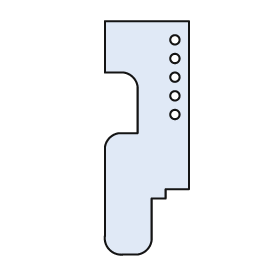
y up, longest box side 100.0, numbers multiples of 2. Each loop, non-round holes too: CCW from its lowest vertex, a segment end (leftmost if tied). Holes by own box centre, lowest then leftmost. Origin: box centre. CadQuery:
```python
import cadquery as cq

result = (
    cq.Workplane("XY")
    .moveTo(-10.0, -50.0)
    .lineTo(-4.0, -50.0)
    .threePointArc((0.0, -48.0), (2.0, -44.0))
    .lineTo(2.0, -26.0)
    .lineTo(8.0, -26.0)
    .lineTo(8.0, -22.0)
    .lineTo(18.0, -22.0)
    .lineTo(18.0, 50.0)
    .lineTo(-18.0, 50.0)
    .lineTo(-18.0, 28.0)
    .lineTo(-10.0, 28.0)
    .threePointArc((-6.0, 26.0), (-4.0, 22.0))
    .lineTo(-4.0, 2.0)
    .lineTo(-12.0, 2.0)
    .threePointArc((-16.0, 0.0), (-18.0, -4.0))
    .lineTo(-18.0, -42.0)
    .threePointArc((-16.0, -48.0), (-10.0, -50.0))
    .close()
    .moveTo(12.0, 10.0)
    .circle(2.0)
    .moveTo(12.0, 18.0)
    .circle(2.0)
    .moveTo(12.0, 26.0)
    .circle(2.0)
    .moveTo(12.0, 34.0)
    .circle(2.0)
    .moveTo(12.0, 42.0)
    .circle(2.0)
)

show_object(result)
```